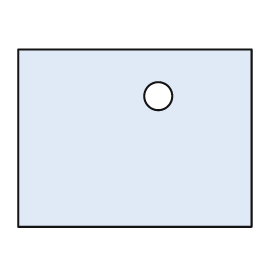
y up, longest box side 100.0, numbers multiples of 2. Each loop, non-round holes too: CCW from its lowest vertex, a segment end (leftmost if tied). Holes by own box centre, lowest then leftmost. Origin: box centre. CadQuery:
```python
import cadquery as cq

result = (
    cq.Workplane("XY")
    .moveTo(-50.0, -38.0)
    .lineTo(50.0, -38.0)
    .lineTo(50.0, 38.0)
    .lineTo(-50.0, 38.0)
    .close()
    .moveTo(10.0, 18.0)
    .circle(6.0)
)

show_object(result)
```